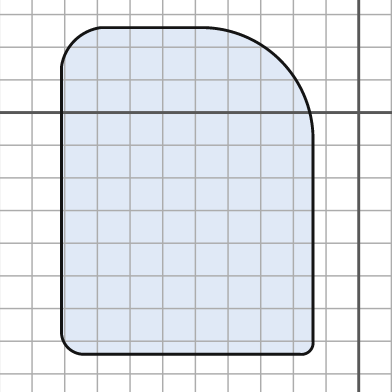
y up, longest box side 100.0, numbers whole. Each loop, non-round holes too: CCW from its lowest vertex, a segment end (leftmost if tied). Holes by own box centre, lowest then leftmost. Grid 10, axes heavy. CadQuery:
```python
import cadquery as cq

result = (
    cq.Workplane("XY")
    .moveTo(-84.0, -74.0)
    .lineTo(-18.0, -74.0)
    .threePointArc((-15.0, -73.0), (-14.0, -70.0))
    .lineTo(-14.0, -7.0)
    .threePointArc((-24.0, 16.0), (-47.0, 26.0))
    .lineTo(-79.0, 26.0)
    .threePointArc((-87.0, 22.0), (-91.0, 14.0))
    .lineTo(-91.0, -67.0)
    .threePointArc((-89.0, -72.0), (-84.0, -74.0))
    .close()
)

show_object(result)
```